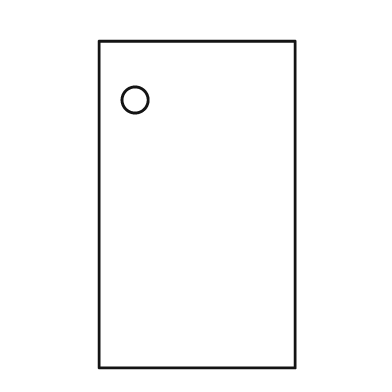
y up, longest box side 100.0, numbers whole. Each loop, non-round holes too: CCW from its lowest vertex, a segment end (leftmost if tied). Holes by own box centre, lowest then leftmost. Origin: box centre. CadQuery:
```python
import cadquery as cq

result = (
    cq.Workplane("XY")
    .moveTo(-30.0, -50.0)
    .lineTo(30.0, -50.0)
    .lineTo(30.0, 50.0)
    .lineTo(-30.0, 50.0)
    .close()
    .moveTo(-19.0, 32.0)
    .circle(4.0)
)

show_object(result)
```